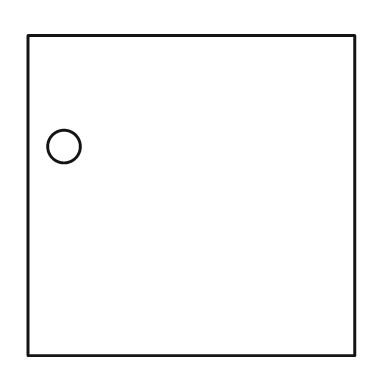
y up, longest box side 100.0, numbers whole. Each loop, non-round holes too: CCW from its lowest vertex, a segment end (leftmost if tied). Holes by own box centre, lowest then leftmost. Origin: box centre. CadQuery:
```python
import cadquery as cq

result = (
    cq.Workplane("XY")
    .moveTo(-50.0, -49.0)
    .lineTo(50.0, -49.0)
    .lineTo(50.0, 49.0)
    .lineTo(-50.0, 49.0)
    .close()
    .moveTo(-39.0, 15.0)
    .circle(5.0)
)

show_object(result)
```